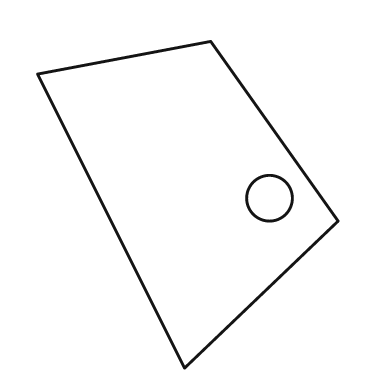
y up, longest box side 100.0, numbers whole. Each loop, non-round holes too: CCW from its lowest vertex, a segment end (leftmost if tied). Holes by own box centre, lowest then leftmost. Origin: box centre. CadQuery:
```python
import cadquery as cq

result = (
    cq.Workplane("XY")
    .moveTo(-1.0, -50.0)
    .lineTo(46.0, -5.0)
    .lineTo(7.0, 50.0)
    .lineTo(-46.0, 40.0)
    .close()
    .moveTo(25.0, 2.0)
    .circle(7.0)
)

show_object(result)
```